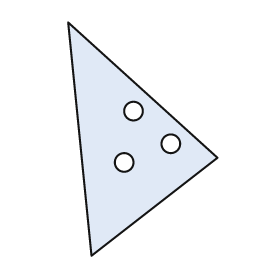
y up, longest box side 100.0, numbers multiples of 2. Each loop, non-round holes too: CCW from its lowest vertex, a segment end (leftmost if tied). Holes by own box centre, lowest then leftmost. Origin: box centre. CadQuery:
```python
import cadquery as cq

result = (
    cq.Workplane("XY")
    .moveTo(-22.0, -50.0)
    .lineTo(32.0, -8.0)
    .lineTo(-32.0, 50.0)
    .close()
    .moveTo(-8.0, -10.0)
    .circle(4.0)
    .moveTo(12.0, -2.0)
    .circle(4.0)
    .moveTo(-4.0, 12.0)
    .circle(4.0)
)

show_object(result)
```